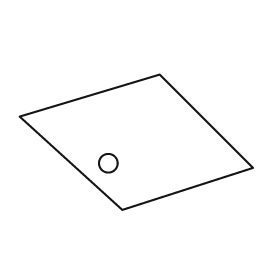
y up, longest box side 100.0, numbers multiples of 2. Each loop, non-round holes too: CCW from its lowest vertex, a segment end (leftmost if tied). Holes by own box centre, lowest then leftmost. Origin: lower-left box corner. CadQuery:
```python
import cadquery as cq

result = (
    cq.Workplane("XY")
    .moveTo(44.0, 0.0)
    .lineTo(100.0, 18.0)
    .lineTo(60.0, 58.0)
    .lineTo(0.0, 40.0)
    .close()
    .moveTo(38.0, 20.0)
    .circle(4.0)
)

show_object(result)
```